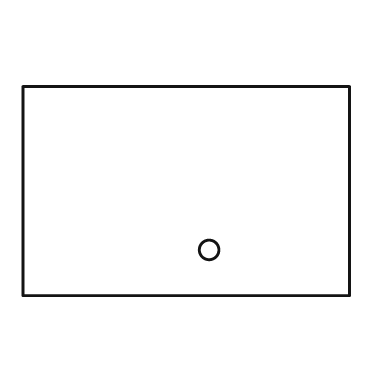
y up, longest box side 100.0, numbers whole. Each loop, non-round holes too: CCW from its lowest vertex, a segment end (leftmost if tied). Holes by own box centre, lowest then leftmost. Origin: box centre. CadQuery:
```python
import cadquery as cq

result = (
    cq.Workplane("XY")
    .moveTo(-50.0, -32.0)
    .lineTo(50.0, -32.0)
    .lineTo(50.0, 32.0)
    .lineTo(-50.0, 32.0)
    .close()
    .moveTo(7.0, -18.0)
    .circle(3.0)
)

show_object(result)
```